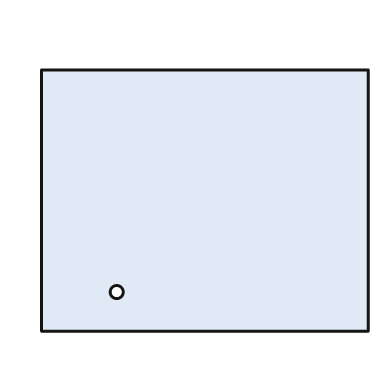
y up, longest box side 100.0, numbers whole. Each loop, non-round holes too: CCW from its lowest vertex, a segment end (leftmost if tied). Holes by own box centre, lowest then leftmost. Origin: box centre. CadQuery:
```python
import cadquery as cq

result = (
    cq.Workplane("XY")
    .moveTo(-50.0, -40.0)
    .lineTo(50.0, -40.0)
    .lineTo(50.0, 40.0)
    .lineTo(-50.0, 40.0)
    .close()
    .moveTo(-27.0, -28.0)
    .circle(2.0)
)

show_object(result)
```